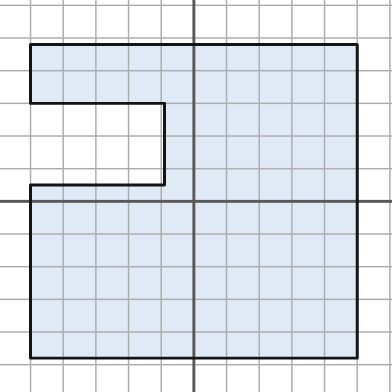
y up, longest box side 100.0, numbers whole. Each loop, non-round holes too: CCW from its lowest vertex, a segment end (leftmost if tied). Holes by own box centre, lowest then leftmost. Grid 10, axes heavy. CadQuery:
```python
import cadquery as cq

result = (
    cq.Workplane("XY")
    .moveTo(-50.0, -48.0)
    .lineTo(50.0, -48.0)
    .lineTo(50.0, 48.0)
    .lineTo(-50.0, 48.0)
    .lineTo(-50.0, 30.0)
    .lineTo(-9.0, 30.0)
    .lineTo(-9.0, 5.0)
    .lineTo(-50.0, 5.0)
    .close()
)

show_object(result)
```